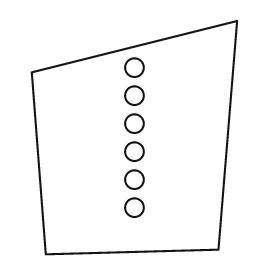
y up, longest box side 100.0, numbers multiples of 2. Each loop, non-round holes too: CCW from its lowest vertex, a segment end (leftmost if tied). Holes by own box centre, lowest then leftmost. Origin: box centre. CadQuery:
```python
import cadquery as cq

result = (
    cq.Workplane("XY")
    .moveTo(-38.0, -50.0)
    .lineTo(36.0, -48.0)
    .lineTo(44.0, 50.0)
    .lineTo(-44.0, 28.0)
    .close()
    .moveTo(0.0, -30.0)
    .circle(4.0)
    .moveTo(0.0, -18.0)
    .circle(4.0)
    .moveTo(0.0, -6.0)
    .circle(4.0)
    .moveTo(0.0, 6.0)
    .circle(4.0)
    .moveTo(0.0, 18.0)
    .circle(4.0)
    .moveTo(0.0, 30.0)
    .circle(4.0)
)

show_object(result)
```